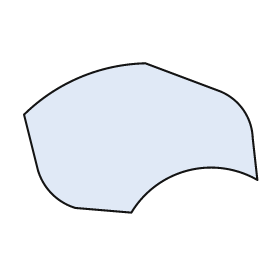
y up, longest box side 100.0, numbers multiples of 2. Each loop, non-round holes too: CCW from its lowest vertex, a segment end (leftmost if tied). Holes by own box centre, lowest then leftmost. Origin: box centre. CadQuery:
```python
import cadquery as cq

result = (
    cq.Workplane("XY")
    .moveTo(-4.0, -32.0)
    .threePointArc((20.0, -14.0), (50.0, -18.0))
    .lineTo(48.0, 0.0)
    .threePointArc((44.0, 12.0), (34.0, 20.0))
    .lineTo(2.0, 32.0)
    .threePointArc((-26.0, 26.0), (-50.0, 10.0))
    .lineTo(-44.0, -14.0)
    .threePointArc((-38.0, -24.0), (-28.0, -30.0))
    .close()
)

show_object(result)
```